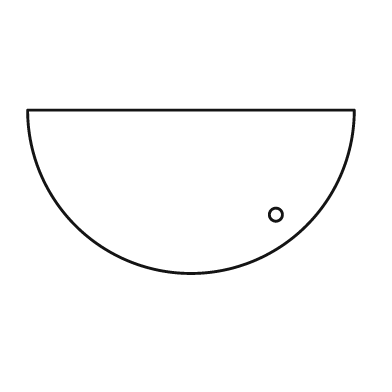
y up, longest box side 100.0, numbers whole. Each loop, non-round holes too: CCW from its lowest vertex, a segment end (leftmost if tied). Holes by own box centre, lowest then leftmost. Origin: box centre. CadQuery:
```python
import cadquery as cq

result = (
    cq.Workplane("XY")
    .moveTo(-50.0, 25.0)
    .threePointArc((0.0, -25.0), (50.0, 25.0))
    .close()
    .moveTo(26.0, -7.0)
    .circle(2.0)
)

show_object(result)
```